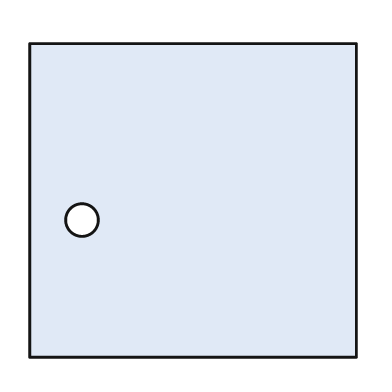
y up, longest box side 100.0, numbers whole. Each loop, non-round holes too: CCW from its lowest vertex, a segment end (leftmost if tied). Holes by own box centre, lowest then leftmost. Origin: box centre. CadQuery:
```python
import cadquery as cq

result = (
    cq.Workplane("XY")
    .moveTo(-50.0, -48.0)
    .lineTo(50.0, -48.0)
    .lineTo(50.0, 48.0)
    .lineTo(-50.0, 48.0)
    .close()
    .moveTo(-34.0, -6.0)
    .circle(5.0)
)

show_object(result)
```